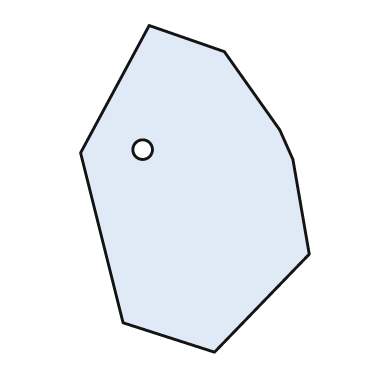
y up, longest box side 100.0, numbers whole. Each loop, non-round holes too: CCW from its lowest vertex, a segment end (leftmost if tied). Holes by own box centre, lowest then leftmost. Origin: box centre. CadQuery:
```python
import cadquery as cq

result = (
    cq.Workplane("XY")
    .moveTo(6.0, -50.0)
    .lineTo(35.0, -20.0)
    .lineTo(30.0, 9.0)
    .lineTo(26.0, 18.0)
    .lineTo(9.0, 42.0)
    .lineTo(-14.0, 50.0)
    .lineTo(-35.0, 11.0)
    .lineTo(-22.0, -41.0)
    .close()
    .moveTo(-16.0, 12.0)
    .circle(3.0)
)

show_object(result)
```